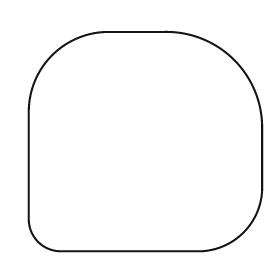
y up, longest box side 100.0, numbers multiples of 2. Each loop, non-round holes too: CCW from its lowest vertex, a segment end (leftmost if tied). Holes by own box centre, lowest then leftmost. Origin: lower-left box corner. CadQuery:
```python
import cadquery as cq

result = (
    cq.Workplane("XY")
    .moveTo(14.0, 0.0)
    .lineTo(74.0, 0.0)
    .threePointArc((92.0, 8.0), (100.0, 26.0))
    .lineTo(100.0, 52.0)
    .threePointArc((88.0, 82.0), (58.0, 94.0))
    .lineTo(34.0, 94.0)
    .threePointArc((10.0, 84.0), (0.0, 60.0))
    .lineTo(0.0, 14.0)
    .threePointArc((4.0, 4.0), (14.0, 0.0))
    .close()
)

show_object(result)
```